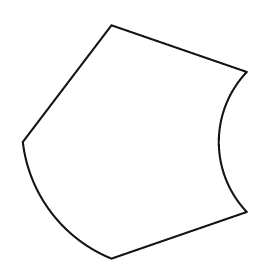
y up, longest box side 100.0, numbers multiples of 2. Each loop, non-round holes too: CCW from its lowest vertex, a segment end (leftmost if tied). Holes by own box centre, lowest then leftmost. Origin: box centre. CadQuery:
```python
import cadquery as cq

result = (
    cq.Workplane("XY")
    .moveTo(-10.0, -50.0)
    .lineTo(48.0, -30.0)
    .threePointArc((36.0, 0.0), (48.0, 30.0))
    .lineTo(-10.0, 50.0)
    .lineTo(-48.0, 0.0)
    .threePointArc((-36.0, -30.0), (-10.0, -50.0))
    .close()
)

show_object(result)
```